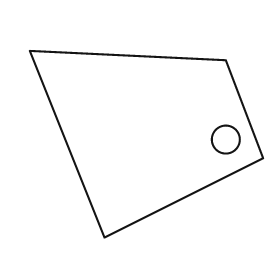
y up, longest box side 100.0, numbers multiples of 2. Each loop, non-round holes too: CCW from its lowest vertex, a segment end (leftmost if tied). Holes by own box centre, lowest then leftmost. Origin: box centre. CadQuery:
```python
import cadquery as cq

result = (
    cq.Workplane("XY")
    .moveTo(-18.0, -40.0)
    .lineTo(50.0, -6.0)
    .lineTo(34.0, 36.0)
    .lineTo(-50.0, 40.0)
    .close()
    .moveTo(34.0, 2.0)
    .circle(6.0)
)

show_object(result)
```